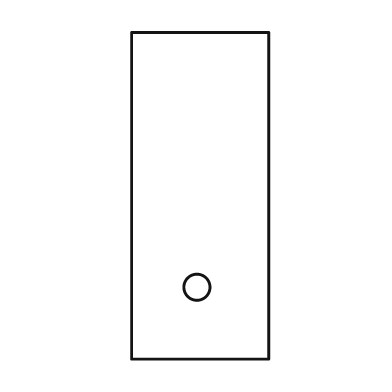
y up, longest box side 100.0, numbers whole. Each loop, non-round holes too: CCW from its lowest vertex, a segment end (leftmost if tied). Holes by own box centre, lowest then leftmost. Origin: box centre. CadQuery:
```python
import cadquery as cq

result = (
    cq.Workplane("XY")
    .moveTo(-21.0, -50.0)
    .lineTo(21.0, -50.0)
    .lineTo(21.0, 50.0)
    .lineTo(-21.0, 50.0)
    .close()
    .moveTo(-1.0, -28.0)
    .circle(4.0)
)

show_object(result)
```